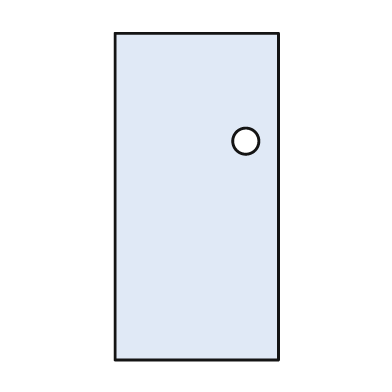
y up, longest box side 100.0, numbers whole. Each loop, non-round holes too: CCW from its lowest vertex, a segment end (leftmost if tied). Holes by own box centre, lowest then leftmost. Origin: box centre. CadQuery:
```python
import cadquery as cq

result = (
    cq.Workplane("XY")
    .moveTo(-25.0, -50.0)
    .lineTo(25.0, -50.0)
    .lineTo(25.0, 50.0)
    .lineTo(-25.0, 50.0)
    .close()
    .moveTo(15.0, 17.0)
    .circle(4.0)
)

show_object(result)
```